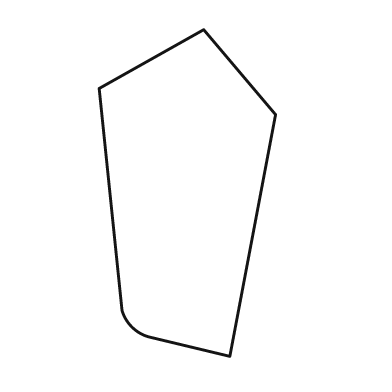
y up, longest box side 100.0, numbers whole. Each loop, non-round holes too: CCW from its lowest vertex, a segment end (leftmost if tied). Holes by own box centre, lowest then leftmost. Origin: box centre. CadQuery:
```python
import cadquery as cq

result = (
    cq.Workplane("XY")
    .moveTo(13.0, -50.0)
    .lineTo(27.0, 24.0)
    .lineTo(5.0, 50.0)
    .lineTo(-27.0, 32.0)
    .lineTo(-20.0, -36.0)
    .threePointArc((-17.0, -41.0), (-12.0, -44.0))
    .close()
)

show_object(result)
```